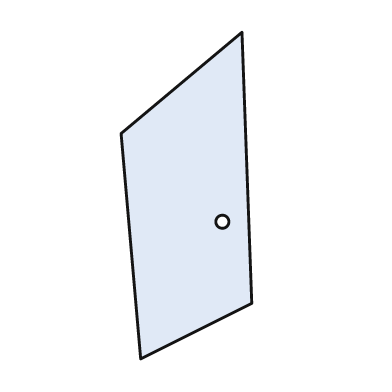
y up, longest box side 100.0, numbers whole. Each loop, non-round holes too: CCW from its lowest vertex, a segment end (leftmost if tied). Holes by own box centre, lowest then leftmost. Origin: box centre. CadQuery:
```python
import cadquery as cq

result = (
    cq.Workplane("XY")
    .moveTo(-14.0, -50.0)
    .lineTo(20.0, -33.0)
    .lineTo(17.0, 50.0)
    .lineTo(-20.0, 19.0)
    .close()
    .moveTo(11.0, -8.0)
    .circle(2.0)
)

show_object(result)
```